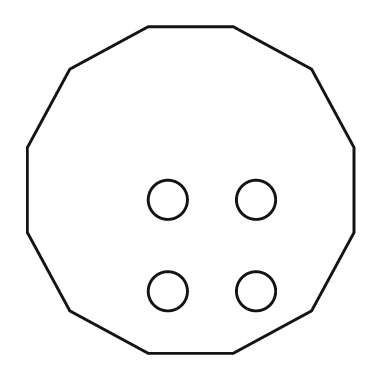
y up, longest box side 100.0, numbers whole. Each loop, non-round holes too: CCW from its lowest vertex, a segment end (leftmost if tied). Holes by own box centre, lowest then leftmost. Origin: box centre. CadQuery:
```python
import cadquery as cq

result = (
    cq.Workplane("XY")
    .moveTo(-13.0, -50.0)
    .lineTo(13.0, -50.0)
    .lineTo(37.0, -37.0)
    .lineTo(50.0, -13.0)
    .lineTo(50.0, 13.0)
    .lineTo(37.0, 37.0)
    .lineTo(13.0, 50.0)
    .lineTo(-13.0, 50.0)
    .lineTo(-37.0, 37.0)
    .lineTo(-50.0, 13.0)
    .lineTo(-50.0, -13.0)
    .lineTo(-37.0, -37.0)
    .close()
    .moveTo(-7.0, -31.0)
    .circle(6.0)
    .moveTo(20.0, -31.0)
    .circle(6.0)
    .moveTo(-7.0, -3.0)
    .circle(6.0)
    .moveTo(20.0, -3.0)
    .circle(6.0)
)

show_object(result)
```